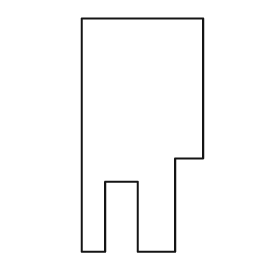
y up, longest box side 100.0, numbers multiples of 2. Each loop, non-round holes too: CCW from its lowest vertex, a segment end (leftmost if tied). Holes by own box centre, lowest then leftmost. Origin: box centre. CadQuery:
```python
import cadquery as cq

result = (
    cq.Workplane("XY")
    .moveTo(-26.0, -50.0)
    .lineTo(-16.0, -50.0)
    .lineTo(-16.0, -20.0)
    .lineTo(-2.0, -20.0)
    .lineTo(-2.0, -50.0)
    .lineTo(14.0, -50.0)
    .lineTo(14.0, -10.0)
    .lineTo(26.0, -10.0)
    .lineTo(26.0, 50.0)
    .lineTo(-26.0, 50.0)
    .close()
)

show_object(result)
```